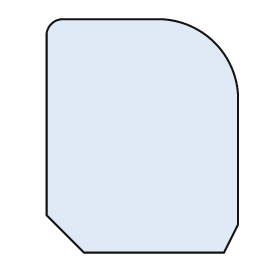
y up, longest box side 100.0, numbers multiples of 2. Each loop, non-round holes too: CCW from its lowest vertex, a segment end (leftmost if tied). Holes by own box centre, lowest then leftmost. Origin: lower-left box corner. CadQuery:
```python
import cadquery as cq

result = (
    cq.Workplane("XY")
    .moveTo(16.0, 0.0)
    .lineTo(76.0, 0.0)
    .lineTo(82.0, 12.0)
    .lineTo(82.0, 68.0)
    .threePointArc((72.0, 90.0), (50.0, 100.0))
    .lineTo(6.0, 100.0)
    .threePointArc((2.0, 98.0), (0.0, 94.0))
    .lineTo(0.0, 16.0)
    .close()
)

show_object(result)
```